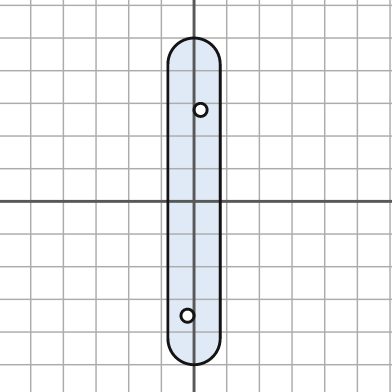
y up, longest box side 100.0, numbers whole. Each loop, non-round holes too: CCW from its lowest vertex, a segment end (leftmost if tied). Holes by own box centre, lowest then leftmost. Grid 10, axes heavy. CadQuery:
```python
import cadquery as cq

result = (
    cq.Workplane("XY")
    .moveTo(-8.0, -42.0)
    .threePointArc((0.0, -50.0), (8.0, -42.0))
    .lineTo(8.0, 42.0)
    .threePointArc((0.0, 50.0), (-8.0, 42.0))
    .close()
    .moveTo(-2.0, -35.0)
    .circle(2.0)
    .moveTo(2.0, 28.0)
    .circle(2.0)
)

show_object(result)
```